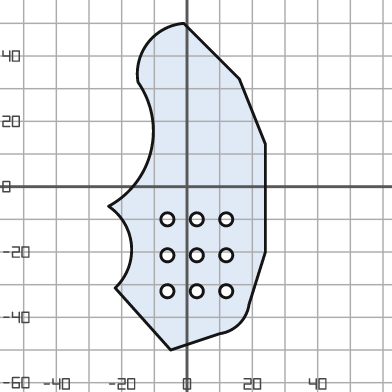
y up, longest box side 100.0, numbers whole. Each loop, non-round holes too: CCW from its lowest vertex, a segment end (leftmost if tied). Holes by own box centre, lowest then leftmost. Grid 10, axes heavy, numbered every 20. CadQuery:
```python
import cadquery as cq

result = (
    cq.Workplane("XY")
    .moveTo(-5.0, -50.0)
    .lineTo(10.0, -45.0)
    .threePointArc((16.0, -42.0), (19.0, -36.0))
    .lineTo(24.0, -20.0)
    .lineTo(24.0, 13.0)
    .lineTo(16.0, 33.0)
    .lineTo(-1.0, 50.0)
    .threePointArc((-12.0, 44.0), (-15.0, 32.0))
    .threePointArc((-11.0, 11.0), (-24.0, -6.0))
    .threePointArc((-17.0, -18.0), (-22.0, -31.0))
    .close()
    .moveTo(-6.0, -32.0)
    .circle(2.0)
    .moveTo(3.0, -32.0)
    .circle(2.0)
    .moveTo(12.0, -32.0)
    .circle(2.0)
    .moveTo(-6.0, -21.0)
    .circle(2.0)
    .moveTo(3.0, -21.0)
    .circle(2.0)
    .moveTo(12.0, -21.0)
    .circle(2.0)
    .moveTo(-6.0, -10.0)
    .circle(2.0)
    .moveTo(3.0, -10.0)
    .circle(2.0)
    .moveTo(12.0, -10.0)
    .circle(2.0)
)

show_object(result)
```